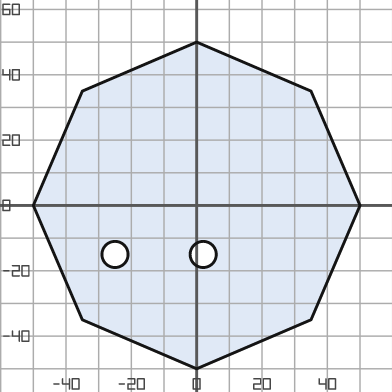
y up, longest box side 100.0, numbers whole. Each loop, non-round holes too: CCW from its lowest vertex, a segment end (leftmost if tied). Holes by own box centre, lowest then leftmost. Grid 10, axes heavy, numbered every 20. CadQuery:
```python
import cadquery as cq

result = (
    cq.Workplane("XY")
    .moveTo(0.0, -50.0)
    .lineTo(35.0, -35.0)
    .lineTo(50.0, 0.0)
    .lineTo(35.0, 35.0)
    .lineTo(0.0, 50.0)
    .lineTo(-35.0, 35.0)
    .lineTo(-50.0, 0.0)
    .lineTo(-35.0, -35.0)
    .close()
    .moveTo(-25.0, -15.0)
    .circle(4.0)
    .moveTo(2.0, -15.0)
    .circle(4.0)
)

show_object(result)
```